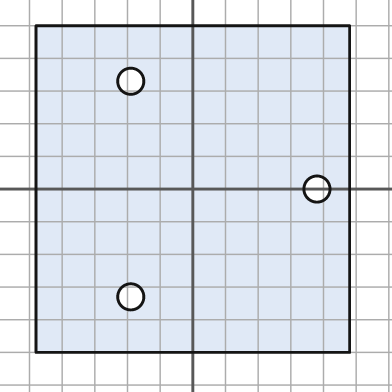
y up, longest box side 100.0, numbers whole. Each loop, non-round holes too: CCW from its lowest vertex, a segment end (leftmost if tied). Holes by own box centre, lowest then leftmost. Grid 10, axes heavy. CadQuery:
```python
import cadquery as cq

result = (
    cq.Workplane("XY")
    .moveTo(-48.0, -50.0)
    .lineTo(48.0, -50.0)
    .lineTo(48.0, 50.0)
    .lineTo(-48.0, 50.0)
    .close()
    .moveTo(-19.0, -33.0)
    .circle(4.0)
    .moveTo(38.0, 0.0)
    .circle(4.0)
    .moveTo(-19.0, 33.0)
    .circle(4.0)
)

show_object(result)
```